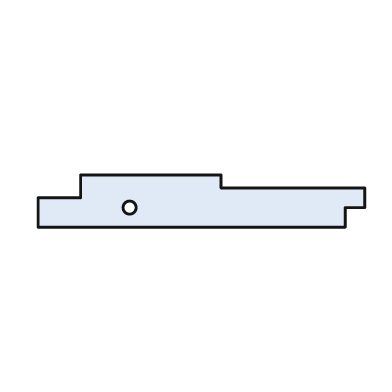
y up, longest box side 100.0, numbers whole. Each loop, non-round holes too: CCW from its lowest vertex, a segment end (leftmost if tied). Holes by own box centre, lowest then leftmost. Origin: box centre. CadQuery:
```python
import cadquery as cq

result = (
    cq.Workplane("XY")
    .moveTo(-50.0, -8.0)
    .lineTo(44.0, -8.0)
    .lineTo(44.0, -2.0)
    .lineTo(50.0, -2.0)
    .lineTo(50.0, 4.0)
    .lineTo(6.0, 4.0)
    .lineTo(6.0, 8.0)
    .lineTo(-37.0, 8.0)
    .lineTo(-37.0, 1.0)
    .lineTo(-50.0, 1.0)
    .close()
    .moveTo(-22.0, -2.0)
    .circle(2.0)
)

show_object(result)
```